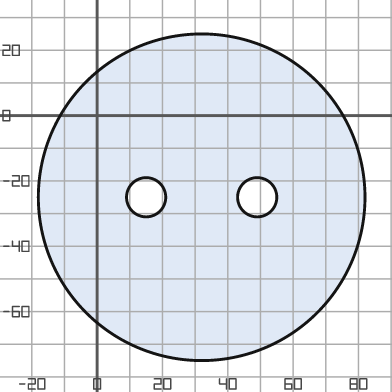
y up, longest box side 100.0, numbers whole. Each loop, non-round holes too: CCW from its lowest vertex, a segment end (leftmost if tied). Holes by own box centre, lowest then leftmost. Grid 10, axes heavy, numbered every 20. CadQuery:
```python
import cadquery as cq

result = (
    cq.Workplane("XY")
    .moveTo(32.0, -25.0)
    .circle(50.0)
    .moveTo(15.0, -25.0)
    .circle(6.0)
    .moveTo(49.0, -25.0)
    .circle(6.0)
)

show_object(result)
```